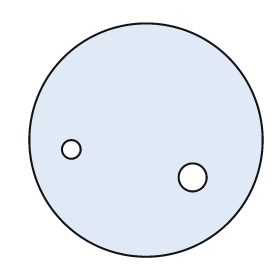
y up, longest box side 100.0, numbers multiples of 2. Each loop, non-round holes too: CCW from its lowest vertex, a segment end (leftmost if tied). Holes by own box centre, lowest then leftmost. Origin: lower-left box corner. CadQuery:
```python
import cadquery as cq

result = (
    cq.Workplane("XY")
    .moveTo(50.0, 50.0)
    .circle(50.0)
    .moveTo(70.0, 34.0)
    .circle(6.0)
    .moveTo(18.0, 46.0)
    .circle(4.0)
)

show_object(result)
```